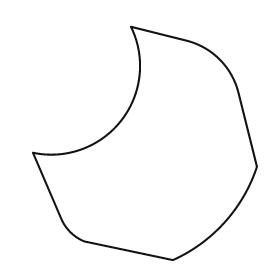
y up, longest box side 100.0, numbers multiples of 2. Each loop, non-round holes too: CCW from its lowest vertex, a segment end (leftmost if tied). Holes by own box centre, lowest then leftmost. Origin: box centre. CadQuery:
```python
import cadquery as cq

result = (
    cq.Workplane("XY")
    .moveTo(12.0, -50.0)
    .threePointArc((34.0, -34.0), (48.0, -10.0))
    .lineTo(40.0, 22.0)
    .threePointArc((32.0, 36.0), (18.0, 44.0))
    .lineTo(-6.0, 50.0)
    .threePointArc((-10.0, 10.0), (-48.0, -4.0))
    .lineTo(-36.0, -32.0)
    .threePointArc((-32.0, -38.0), (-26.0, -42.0))
    .close()
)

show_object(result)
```